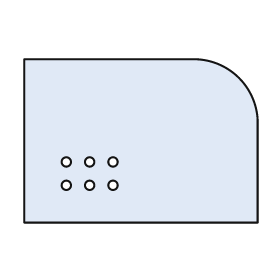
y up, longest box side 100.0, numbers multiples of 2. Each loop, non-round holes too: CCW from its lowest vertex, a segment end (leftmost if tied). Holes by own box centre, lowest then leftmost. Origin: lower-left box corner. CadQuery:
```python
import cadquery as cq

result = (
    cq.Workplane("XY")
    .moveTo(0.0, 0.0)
    .lineTo(100.0, 0.0)
    .lineTo(100.0, 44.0)
    .threePointArc((92.0, 62.0), (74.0, 70.0))
    .lineTo(0.0, 70.0)
    .close()
    .moveTo(18.0, 16.0)
    .circle(2.0)
    .moveTo(28.0, 16.0)
    .circle(2.0)
    .moveTo(38.0, 16.0)
    .circle(2.0)
    .moveTo(18.0, 26.0)
    .circle(2.0)
    .moveTo(28.0, 26.0)
    .circle(2.0)
    .moveTo(38.0, 26.0)
    .circle(2.0)
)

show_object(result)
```